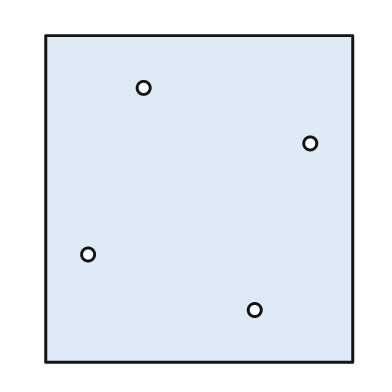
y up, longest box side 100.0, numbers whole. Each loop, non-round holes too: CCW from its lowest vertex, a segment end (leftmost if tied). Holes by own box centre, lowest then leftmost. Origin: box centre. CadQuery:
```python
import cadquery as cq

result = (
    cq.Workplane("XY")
    .moveTo(-47.0, -50.0)
    .lineTo(47.0, -50.0)
    .lineTo(47.0, 50.0)
    .lineTo(-47.0, 50.0)
    .close()
    .moveTo(17.0, -34.0)
    .circle(2.0)
    .moveTo(-34.0, -17.0)
    .circle(2.0)
    .moveTo(34.0, 17.0)
    .circle(2.0)
    .moveTo(-17.0, 34.0)
    .circle(2.0)
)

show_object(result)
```